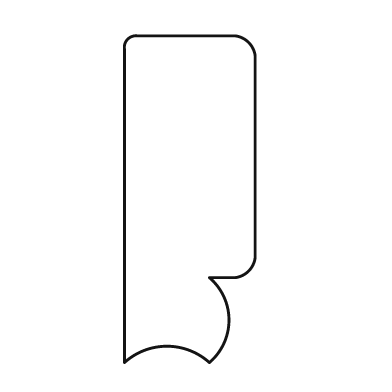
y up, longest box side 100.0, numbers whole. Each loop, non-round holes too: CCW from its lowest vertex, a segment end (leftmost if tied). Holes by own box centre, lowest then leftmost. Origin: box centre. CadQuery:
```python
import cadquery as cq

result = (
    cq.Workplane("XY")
    .moveTo(-20.0, -50.0)
    .threePointArc((-7.0, -45.0), (6.0, -50.0))
    .threePointArc((12.0, -37.0), (6.0, -24.0))
    .lineTo(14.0, -24.0)
    .threePointArc((18.0, -22.0), (20.0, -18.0))
    .lineTo(20.0, 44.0)
    .threePointArc((18.0, 48.0), (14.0, 50.0))
    .lineTo(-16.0, 50.0)
    .threePointArc((-19.0, 49.0), (-20.0, 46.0))
    .close()
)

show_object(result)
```